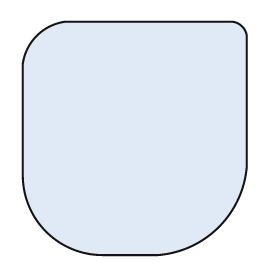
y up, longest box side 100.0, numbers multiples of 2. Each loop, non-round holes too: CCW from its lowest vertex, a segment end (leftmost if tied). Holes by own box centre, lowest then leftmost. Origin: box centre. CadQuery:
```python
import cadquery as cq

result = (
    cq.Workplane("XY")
    .moveTo(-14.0, -50.0)
    .lineTo(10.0, -50.0)
    .threePointArc((36.0, -38.0), (48.0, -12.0))
    .lineTo(48.0, 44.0)
    .threePointArc((46.0, 48.0), (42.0, 50.0))
    .lineTo(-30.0, 50.0)
    .threePointArc((-42.0, 44.0), (-48.0, 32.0))
    .lineTo(-48.0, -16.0)
    .threePointArc((-38.0, -40.0), (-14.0, -50.0))
    .close()
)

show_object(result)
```